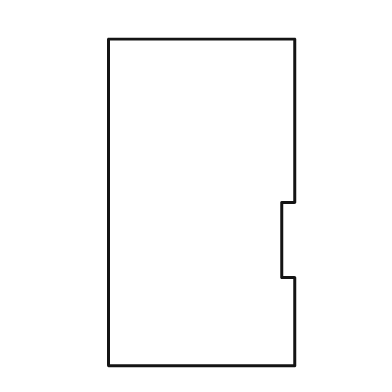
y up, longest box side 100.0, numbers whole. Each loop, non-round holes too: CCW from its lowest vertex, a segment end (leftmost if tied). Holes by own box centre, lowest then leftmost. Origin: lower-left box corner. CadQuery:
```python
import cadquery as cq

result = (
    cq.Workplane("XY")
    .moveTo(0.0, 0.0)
    .lineTo(57.0, 0.0)
    .lineTo(57.0, 27.0)
    .lineTo(53.0, 27.0)
    .lineTo(53.0, 50.0)
    .lineTo(57.0, 50.0)
    .lineTo(57.0, 100.0)
    .lineTo(0.0, 100.0)
    .close()
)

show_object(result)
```